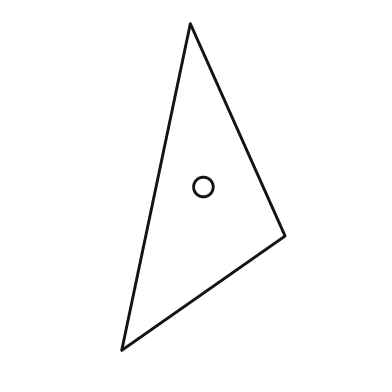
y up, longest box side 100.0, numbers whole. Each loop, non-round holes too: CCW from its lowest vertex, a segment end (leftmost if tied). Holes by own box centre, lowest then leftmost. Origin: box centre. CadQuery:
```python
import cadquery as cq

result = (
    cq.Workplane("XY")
    .moveTo(-25.0, -50.0)
    .lineTo(25.0, -15.0)
    .lineTo(-4.0, 50.0)
    .close()
    .moveTo(0.0, 0.0)
    .circle(3.0)
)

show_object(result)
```